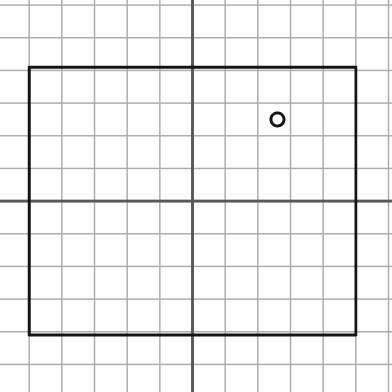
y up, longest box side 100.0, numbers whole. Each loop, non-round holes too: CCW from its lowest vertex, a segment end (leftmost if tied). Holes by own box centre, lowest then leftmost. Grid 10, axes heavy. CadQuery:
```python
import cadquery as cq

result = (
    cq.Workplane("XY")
    .moveTo(-50.0, -41.0)
    .lineTo(50.0, -41.0)
    .lineTo(50.0, 41.0)
    .lineTo(-50.0, 41.0)
    .close()
    .moveTo(26.0, 25.0)
    .circle(2.0)
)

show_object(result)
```